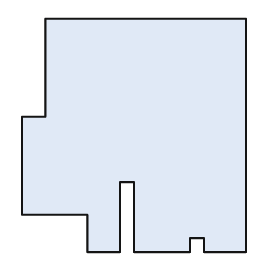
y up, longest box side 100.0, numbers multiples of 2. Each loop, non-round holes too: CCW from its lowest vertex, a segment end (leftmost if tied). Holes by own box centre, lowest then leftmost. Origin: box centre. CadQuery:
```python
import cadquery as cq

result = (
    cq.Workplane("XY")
    .moveTo(-20.0, -50.0)
    .lineTo(-6.0, -50.0)
    .lineTo(-6.0, -20.0)
    .lineTo(0.0, -20.0)
    .lineTo(0.0, -50.0)
    .lineTo(24.0, -50.0)
    .lineTo(24.0, -44.0)
    .lineTo(30.0, -44.0)
    .lineTo(30.0, -50.0)
    .lineTo(48.0, -50.0)
    .lineTo(48.0, 50.0)
    .lineTo(-38.0, 50.0)
    .lineTo(-38.0, 8.0)
    .lineTo(-48.0, 8.0)
    .lineTo(-48.0, -34.0)
    .lineTo(-20.0, -34.0)
    .close()
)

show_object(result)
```